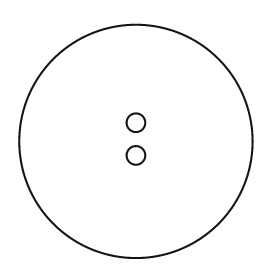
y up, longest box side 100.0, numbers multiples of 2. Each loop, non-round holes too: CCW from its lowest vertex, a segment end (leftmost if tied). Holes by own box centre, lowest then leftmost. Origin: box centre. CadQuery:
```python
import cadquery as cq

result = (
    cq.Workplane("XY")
    .moveTo(0.0, 0.0)
    .circle(50.0)
    .moveTo(0.0, -6.0)
    .circle(4.0)
    .moveTo(0.0, 8.0)
    .circle(4.0)
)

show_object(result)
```